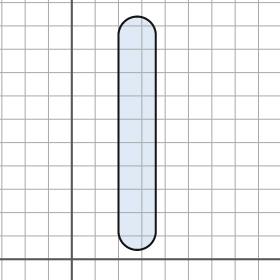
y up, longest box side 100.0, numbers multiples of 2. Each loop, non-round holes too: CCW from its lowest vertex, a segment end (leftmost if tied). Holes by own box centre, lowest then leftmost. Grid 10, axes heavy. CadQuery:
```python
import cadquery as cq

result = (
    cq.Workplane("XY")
    .moveTo(20.0, 12.0)
    .threePointArc((28.0, 4.0), (36.0, 12.0))
    .lineTo(36.0, 96.0)
    .threePointArc((28.0, 104.0), (20.0, 96.0))
    .close()
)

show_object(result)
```